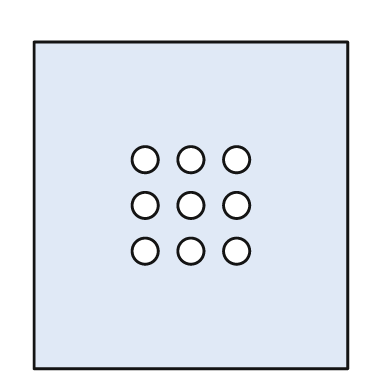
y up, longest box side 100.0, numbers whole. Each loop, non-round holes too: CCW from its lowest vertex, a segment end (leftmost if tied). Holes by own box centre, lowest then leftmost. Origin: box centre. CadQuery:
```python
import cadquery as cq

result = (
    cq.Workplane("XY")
    .moveTo(-48.0, -50.0)
    .lineTo(48.0, -50.0)
    .lineTo(48.0, 50.0)
    .lineTo(-48.0, 50.0)
    .close()
    .moveTo(-14.0, -14.0)
    .circle(4.0)
    .moveTo(0.0, -14.0)
    .circle(4.0)
    .moveTo(14.0, -14.0)
    .circle(4.0)
    .moveTo(-14.0, 0.0)
    .circle(4.0)
    .moveTo(0.0, 0.0)
    .circle(4.0)
    .moveTo(14.0, 0.0)
    .circle(4.0)
    .moveTo(-14.0, 14.0)
    .circle(4.0)
    .moveTo(0.0, 14.0)
    .circle(4.0)
    .moveTo(14.0, 14.0)
    .circle(4.0)
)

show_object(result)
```